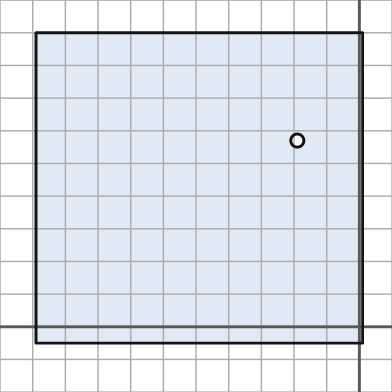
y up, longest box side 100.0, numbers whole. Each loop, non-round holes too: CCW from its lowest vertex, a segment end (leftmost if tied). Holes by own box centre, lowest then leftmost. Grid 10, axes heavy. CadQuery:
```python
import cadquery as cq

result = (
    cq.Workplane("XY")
    .moveTo(-99.0, -5.0)
    .lineTo(1.0, -5.0)
    .lineTo(1.0, 90.0)
    .lineTo(-99.0, 90.0)
    .close()
    .moveTo(-19.0, 57.0)
    .circle(2.0)
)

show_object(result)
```